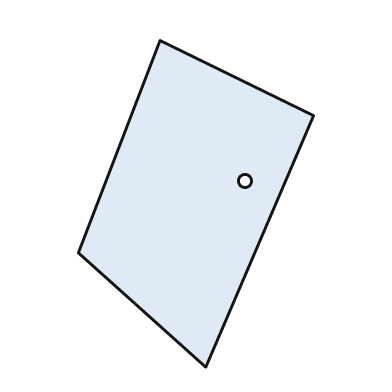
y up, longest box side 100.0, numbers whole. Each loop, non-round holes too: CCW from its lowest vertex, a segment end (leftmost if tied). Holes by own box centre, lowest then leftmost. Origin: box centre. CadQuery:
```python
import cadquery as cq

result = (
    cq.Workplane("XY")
    .moveTo(3.0, -50.0)
    .lineTo(36.0, 27.0)
    .lineTo(-11.0, 50.0)
    .lineTo(-36.0, -15.0)
    .close()
    .moveTo(15.0, 7.0)
    .circle(2.0)
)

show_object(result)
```